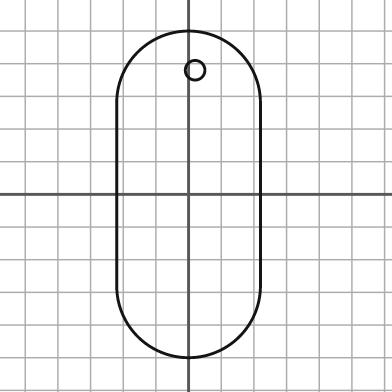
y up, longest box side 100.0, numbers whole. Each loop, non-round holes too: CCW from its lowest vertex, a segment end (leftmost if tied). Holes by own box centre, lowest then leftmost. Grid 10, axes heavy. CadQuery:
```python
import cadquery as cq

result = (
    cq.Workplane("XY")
    .moveTo(-22.0, -28.0)
    .threePointArc((0.0, -50.0), (22.0, -28.0))
    .lineTo(22.0, 28.0)
    .threePointArc((0.0, 50.0), (-22.0, 28.0))
    .close()
    .moveTo(2.0, 38.0)
    .circle(3.0)
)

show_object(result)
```